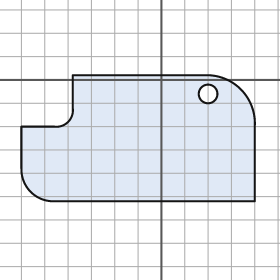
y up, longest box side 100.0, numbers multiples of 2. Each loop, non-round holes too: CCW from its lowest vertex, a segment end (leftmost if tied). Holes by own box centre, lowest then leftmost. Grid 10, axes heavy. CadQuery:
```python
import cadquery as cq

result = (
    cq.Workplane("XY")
    .moveTo(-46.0, -52.0)
    .lineTo(40.0, -52.0)
    .lineTo(40.0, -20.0)
    .threePointArc((34.0, -4.0), (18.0, 2.0))
    .lineTo(-38.0, 2.0)
    .lineTo(-38.0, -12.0)
    .threePointArc((-40.0, -18.0), (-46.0, -20.0))
    .lineTo(-60.0, -20.0)
    .lineTo(-60.0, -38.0)
    .threePointArc((-56.0, -48.0), (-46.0, -52.0))
    .close()
    .moveTo(20.0, -6.0)
    .circle(4.0)
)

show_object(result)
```